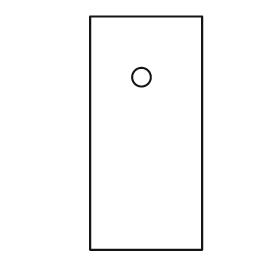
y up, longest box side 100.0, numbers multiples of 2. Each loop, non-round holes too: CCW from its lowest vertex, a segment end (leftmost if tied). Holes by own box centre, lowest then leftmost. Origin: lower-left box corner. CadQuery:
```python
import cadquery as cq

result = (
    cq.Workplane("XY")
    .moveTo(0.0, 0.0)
    .lineTo(48.0, 0.0)
    .lineTo(48.0, 100.0)
    .lineTo(0.0, 100.0)
    .close()
    .moveTo(22.0, 74.0)
    .circle(4.0)
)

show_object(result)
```